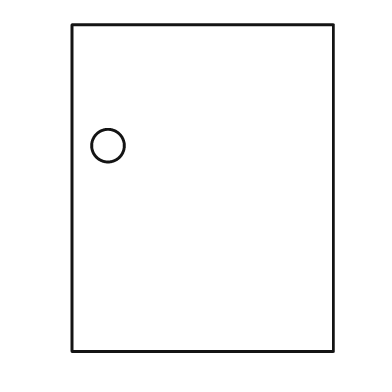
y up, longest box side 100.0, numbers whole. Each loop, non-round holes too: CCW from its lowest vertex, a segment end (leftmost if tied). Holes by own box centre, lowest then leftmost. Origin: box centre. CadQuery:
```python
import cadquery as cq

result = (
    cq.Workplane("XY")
    .moveTo(-40.0, -50.0)
    .lineTo(40.0, -50.0)
    .lineTo(40.0, 50.0)
    .lineTo(-40.0, 50.0)
    .close()
    .moveTo(-29.0, 13.0)
    .circle(5.0)
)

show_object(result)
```